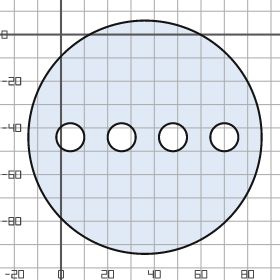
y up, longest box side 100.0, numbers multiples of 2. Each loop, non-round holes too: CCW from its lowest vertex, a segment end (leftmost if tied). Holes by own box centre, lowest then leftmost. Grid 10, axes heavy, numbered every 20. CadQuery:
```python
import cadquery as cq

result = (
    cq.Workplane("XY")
    .moveTo(36.0, -44.0)
    .circle(50.0)
    .moveTo(4.0, -44.0)
    .circle(6.0)
    .moveTo(26.0, -44.0)
    .circle(6.0)
    .moveTo(48.0, -44.0)
    .circle(6.0)
    .moveTo(70.0, -44.0)
    .circle(6.0)
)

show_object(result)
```